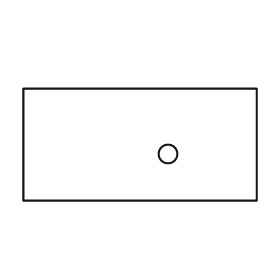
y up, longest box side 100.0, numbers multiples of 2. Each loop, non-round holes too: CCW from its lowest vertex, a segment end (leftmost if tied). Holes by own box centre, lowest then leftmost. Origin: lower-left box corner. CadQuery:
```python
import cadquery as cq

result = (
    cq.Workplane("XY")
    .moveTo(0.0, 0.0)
    .lineTo(100.0, 0.0)
    .lineTo(100.0, 48.0)
    .lineTo(0.0, 48.0)
    .close()
    .moveTo(62.0, 20.0)
    .circle(4.0)
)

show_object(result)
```